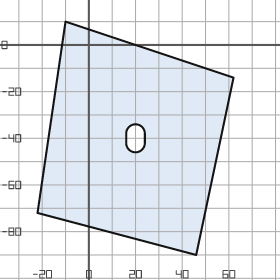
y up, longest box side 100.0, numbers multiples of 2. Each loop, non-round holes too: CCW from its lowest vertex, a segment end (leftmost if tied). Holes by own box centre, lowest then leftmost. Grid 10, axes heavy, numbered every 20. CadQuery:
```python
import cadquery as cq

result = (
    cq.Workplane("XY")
    .moveTo(46.0, -90.0)
    .lineTo(62.0, -14.0)
    .lineTo(-10.0, 10.0)
    .lineTo(-22.0, -72.0)
    .close()
    .moveTo(16.0, -42.0)
    .threePointArc((20.0, -46.0), (24.0, -42.0))
    .lineTo(24.0, -38.0)
    .threePointArc((20.0, -34.0), (16.0, -38.0))
    .close()
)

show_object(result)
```